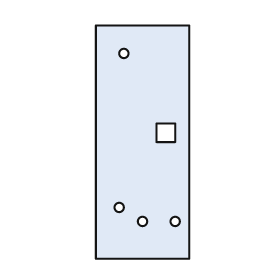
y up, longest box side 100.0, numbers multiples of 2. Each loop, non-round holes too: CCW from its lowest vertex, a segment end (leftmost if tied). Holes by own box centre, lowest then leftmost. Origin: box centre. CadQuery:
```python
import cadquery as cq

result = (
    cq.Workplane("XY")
    .moveTo(-20.0, -50.0)
    .lineTo(20.0, -50.0)
    .lineTo(20.0, 50.0)
    .lineTo(-20.0, 50.0)
    .close()
    .moveTo(0.0, -34.0)
    .circle(2.0)
    .moveTo(14.0, -34.0)
    .circle(2.0)
    .moveTo(-10.0, -28.0)
    .circle(2.0)
    .moveTo(6.0, 0.0)
    .lineTo(14.0, 0.0)
    .lineTo(14.0, 8.0)
    .lineTo(6.0, 8.0)
    .close()
    .moveTo(-8.0, 38.0)
    .circle(2.0)
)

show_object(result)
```